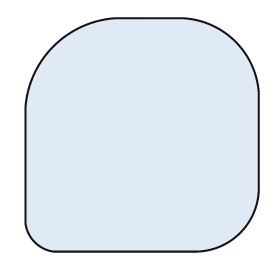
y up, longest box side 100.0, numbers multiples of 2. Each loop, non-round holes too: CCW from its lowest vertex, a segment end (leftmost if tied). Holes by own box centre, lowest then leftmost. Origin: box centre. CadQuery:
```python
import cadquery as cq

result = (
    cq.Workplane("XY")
    .moveTo(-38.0, -50.0)
    .lineTo(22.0, -50.0)
    .threePointArc((42.0, -42.0), (50.0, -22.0))
    .lineTo(50.0, 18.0)
    .threePointArc((40.0, 40.0), (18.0, 50.0))
    .lineTo(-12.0, 50.0)
    .threePointArc((-38.0, 38.0), (-50.0, 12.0))
    .lineTo(-50.0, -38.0)
    .threePointArc((-46.0, -46.0), (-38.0, -50.0))
    .close()
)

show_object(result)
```